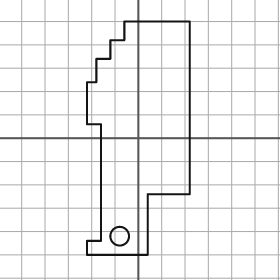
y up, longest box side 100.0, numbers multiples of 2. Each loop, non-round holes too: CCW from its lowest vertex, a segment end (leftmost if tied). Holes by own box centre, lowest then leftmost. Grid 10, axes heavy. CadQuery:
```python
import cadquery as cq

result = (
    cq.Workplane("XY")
    .moveTo(-22.0, -50.0)
    .lineTo(4.0, -50.0)
    .lineTo(4.0, -24.0)
    .lineTo(22.0, -24.0)
    .lineTo(22.0, 50.0)
    .lineTo(-6.0, 50.0)
    .lineTo(-6.0, 42.0)
    .lineTo(-12.0, 42.0)
    .lineTo(-12.0, 34.0)
    .lineTo(-18.0, 34.0)
    .lineTo(-18.0, 24.0)
    .lineTo(-22.0, 24.0)
    .lineTo(-22.0, 6.0)
    .lineTo(-16.0, 6.0)
    .lineTo(-16.0, -44.0)
    .lineTo(-22.0, -44.0)
    .close()
    .moveTo(-8.0, -42.0)
    .circle(4.0)
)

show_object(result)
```